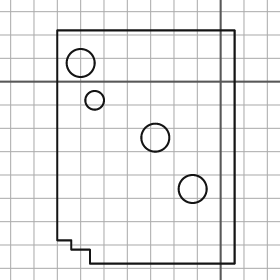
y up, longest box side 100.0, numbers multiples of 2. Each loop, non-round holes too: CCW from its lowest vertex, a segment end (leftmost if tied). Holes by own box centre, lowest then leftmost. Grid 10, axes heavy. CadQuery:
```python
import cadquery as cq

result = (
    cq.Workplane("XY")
    .moveTo(-56.0, -78.0)
    .lineTo(6.0, -78.0)
    .lineTo(6.0, 22.0)
    .lineTo(-70.0, 22.0)
    .lineTo(-70.0, -68.0)
    .lineTo(-64.0, -68.0)
    .lineTo(-64.0, -72.0)
    .lineTo(-56.0, -72.0)
    .close()
    .moveTo(-12.0, -46.0)
    .circle(6.0)
    .moveTo(-28.0, -24.0)
    .circle(6.0)
    .moveTo(-54.0, -8.0)
    .circle(4.0)
    .moveTo(-60.0, 8.0)
    .circle(6.0)
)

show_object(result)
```